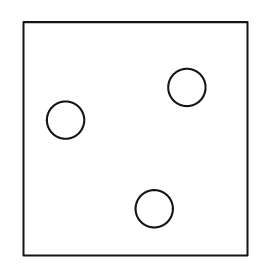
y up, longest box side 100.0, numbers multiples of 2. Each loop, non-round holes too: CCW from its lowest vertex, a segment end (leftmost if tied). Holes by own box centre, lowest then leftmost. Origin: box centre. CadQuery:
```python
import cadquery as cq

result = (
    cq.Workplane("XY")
    .moveTo(-48.0, -50.0)
    .lineTo(48.0, -50.0)
    .lineTo(48.0, 50.0)
    .lineTo(-48.0, 50.0)
    .close()
    .moveTo(8.0, -30.0)
    .circle(8.0)
    .moveTo(-30.0, 8.0)
    .circle(8.0)
    .moveTo(22.0, 22.0)
    .circle(8.0)
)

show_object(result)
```